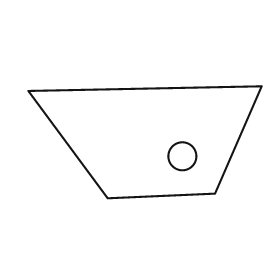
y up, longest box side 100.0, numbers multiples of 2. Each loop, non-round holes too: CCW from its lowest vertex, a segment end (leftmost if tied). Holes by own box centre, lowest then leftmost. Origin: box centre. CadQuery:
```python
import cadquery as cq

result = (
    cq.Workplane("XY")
    .moveTo(-16.0, -24.0)
    .lineTo(30.0, -22.0)
    .lineTo(50.0, 24.0)
    .lineTo(-50.0, 22.0)
    .close()
    .moveTo(16.0, -6.0)
    .circle(6.0)
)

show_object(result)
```